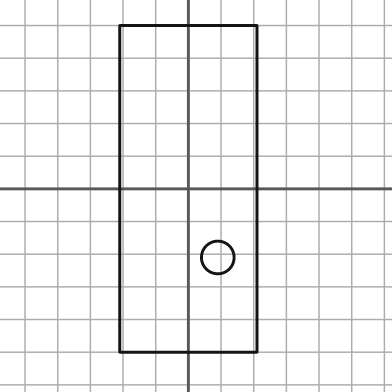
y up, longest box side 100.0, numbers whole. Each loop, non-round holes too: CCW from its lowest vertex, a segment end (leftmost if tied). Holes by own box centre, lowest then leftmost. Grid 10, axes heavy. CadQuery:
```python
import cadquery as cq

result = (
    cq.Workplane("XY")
    .moveTo(-21.0, -50.0)
    .lineTo(21.0, -50.0)
    .lineTo(21.0, 50.0)
    .lineTo(-21.0, 50.0)
    .close()
    .moveTo(9.0, -21.0)
    .circle(5.0)
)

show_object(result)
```